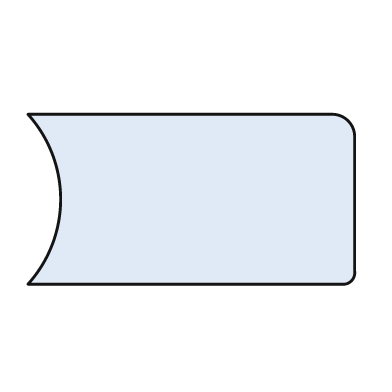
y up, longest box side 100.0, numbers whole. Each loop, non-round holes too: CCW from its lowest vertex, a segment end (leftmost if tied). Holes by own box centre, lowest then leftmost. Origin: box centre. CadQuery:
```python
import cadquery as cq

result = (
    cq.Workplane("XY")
    .moveTo(-50.0, -26.0)
    .lineTo(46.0, -26.0)
    .threePointArc((49.0, -25.0), (50.0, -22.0))
    .lineTo(50.0, 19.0)
    .threePointArc((48.0, 24.0), (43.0, 26.0))
    .lineTo(-50.0, 26.0)
    .threePointArc((-40.0, 0.0), (-50.0, -26.0))
    .close()
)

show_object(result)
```